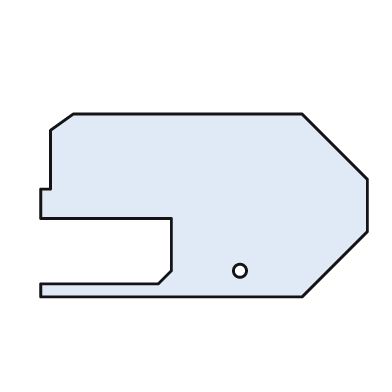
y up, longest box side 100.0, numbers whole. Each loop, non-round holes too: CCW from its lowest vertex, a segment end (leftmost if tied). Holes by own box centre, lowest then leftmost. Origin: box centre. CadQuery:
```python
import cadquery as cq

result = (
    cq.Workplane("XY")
    .moveTo(-50.0, -28.0)
    .lineTo(30.0, -28.0)
    .lineTo(50.0, -8.0)
    .lineTo(50.0, 8.0)
    .lineTo(30.0, 28.0)
    .lineTo(-40.0, 28.0)
    .lineTo(-47.0, 23.0)
    .lineTo(-47.0, 5.0)
    .lineTo(-50.0, 5.0)
    .lineTo(-50.0, -4.0)
    .lineTo(-10.0, -4.0)
    .lineTo(-10.0, -20.0)
    .lineTo(-14.0, -24.0)
    .lineTo(-50.0, -24.0)
    .close()
    .moveTo(11.0, -20.0)
    .circle(2.0)
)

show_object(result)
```